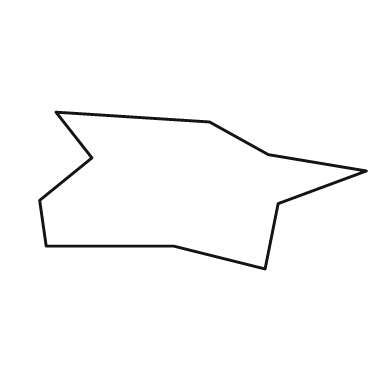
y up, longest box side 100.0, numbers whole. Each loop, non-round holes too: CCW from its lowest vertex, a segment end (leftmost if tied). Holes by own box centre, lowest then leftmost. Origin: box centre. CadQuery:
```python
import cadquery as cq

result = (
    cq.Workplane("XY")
    .moveTo(19.0, -24.0)
    .lineTo(23.0, -4.0)
    .lineTo(50.0, 6.0)
    .lineTo(20.0, 11.0)
    .lineTo(2.0, 21.0)
    .lineTo(-45.0, 24.0)
    .lineTo(-34.0, 10.0)
    .lineTo(-50.0, -3.0)
    .lineTo(-48.0, -17.0)
    .lineTo(-9.0, -17.0)
    .close()
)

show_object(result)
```